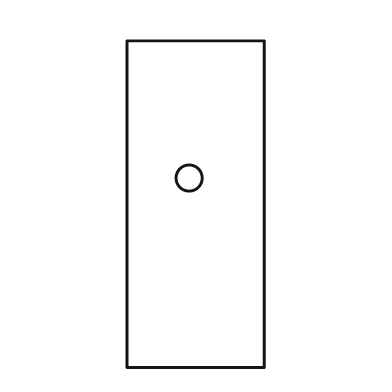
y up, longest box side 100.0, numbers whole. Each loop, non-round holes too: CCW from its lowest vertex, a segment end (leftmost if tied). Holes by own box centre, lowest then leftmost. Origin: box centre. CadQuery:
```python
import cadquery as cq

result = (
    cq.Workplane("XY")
    .moveTo(-21.0, -50.0)
    .lineTo(21.0, -50.0)
    .lineTo(21.0, 50.0)
    .lineTo(-21.0, 50.0)
    .close()
    .moveTo(-2.0, 8.0)
    .circle(4.0)
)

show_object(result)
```